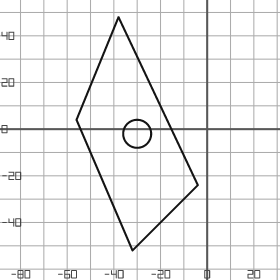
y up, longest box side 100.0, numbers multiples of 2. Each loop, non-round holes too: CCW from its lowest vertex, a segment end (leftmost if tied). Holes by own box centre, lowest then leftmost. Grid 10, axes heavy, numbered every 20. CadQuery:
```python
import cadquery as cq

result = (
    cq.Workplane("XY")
    .moveTo(-32.0, -52.0)
    .lineTo(-4.0, -24.0)
    .lineTo(-38.0, 48.0)
    .lineTo(-56.0, 4.0)
    .close()
    .moveTo(-30.0, -2.0)
    .circle(6.0)
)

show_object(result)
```